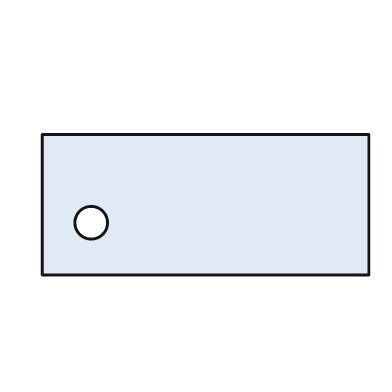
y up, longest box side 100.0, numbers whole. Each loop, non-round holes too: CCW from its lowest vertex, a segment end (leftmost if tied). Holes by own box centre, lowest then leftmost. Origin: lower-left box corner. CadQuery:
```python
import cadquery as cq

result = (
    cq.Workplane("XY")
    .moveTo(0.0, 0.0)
    .lineTo(100.0, 0.0)
    .lineTo(100.0, 43.0)
    .lineTo(0.0, 43.0)
    .close()
    .moveTo(15.0, 16.0)
    .circle(5.0)
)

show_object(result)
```